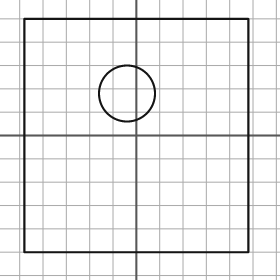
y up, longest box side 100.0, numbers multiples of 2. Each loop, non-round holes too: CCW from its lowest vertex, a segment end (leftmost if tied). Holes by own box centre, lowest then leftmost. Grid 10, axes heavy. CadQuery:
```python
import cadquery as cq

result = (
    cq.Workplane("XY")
    .moveTo(-48.0, -50.0)
    .lineTo(48.0, -50.0)
    .lineTo(48.0, 50.0)
    .lineTo(-48.0, 50.0)
    .close()
    .moveTo(-4.0, 18.0)
    .circle(12.0)
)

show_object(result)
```